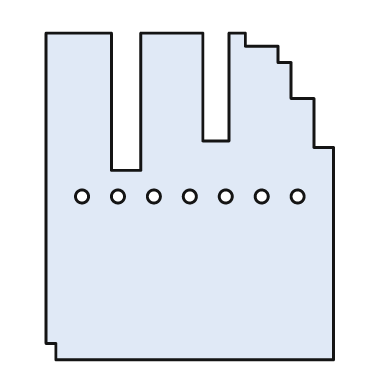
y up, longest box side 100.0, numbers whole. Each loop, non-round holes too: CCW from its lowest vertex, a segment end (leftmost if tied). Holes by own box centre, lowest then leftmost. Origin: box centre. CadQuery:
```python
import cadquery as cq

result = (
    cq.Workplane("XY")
    .moveTo(-41.0, -50.0)
    .lineTo(44.0, -50.0)
    .lineTo(44.0, 15.0)
    .lineTo(38.0, 15.0)
    .lineTo(38.0, 30.0)
    .lineTo(31.0, 30.0)
    .lineTo(31.0, 41.0)
    .lineTo(27.0, 41.0)
    .lineTo(27.0, 46.0)
    .lineTo(17.0, 46.0)
    .lineTo(17.0, 50.0)
    .lineTo(12.0, 50.0)
    .lineTo(12.0, 17.0)
    .lineTo(4.0, 17.0)
    .lineTo(4.0, 50.0)
    .lineTo(-15.0, 50.0)
    .lineTo(-15.0, 8.0)
    .lineTo(-24.0, 8.0)
    .lineTo(-24.0, 50.0)
    .lineTo(-44.0, 50.0)
    .lineTo(-44.0, -45.0)
    .lineTo(-41.0, -45.0)
    .close()
    .moveTo(-33.0, 0.0)
    .circle(2.0)
    .moveTo(-22.0, 0.0)
    .circle(2.0)
    .moveTo(-11.0, 0.0)
    .circle(2.0)
    .moveTo(0.0, 0.0)
    .circle(2.0)
    .moveTo(11.0, 0.0)
    .circle(2.0)
    .moveTo(22.0, 0.0)
    .circle(2.0)
    .moveTo(33.0, 0.0)
    .circle(2.0)
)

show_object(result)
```